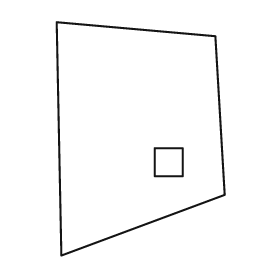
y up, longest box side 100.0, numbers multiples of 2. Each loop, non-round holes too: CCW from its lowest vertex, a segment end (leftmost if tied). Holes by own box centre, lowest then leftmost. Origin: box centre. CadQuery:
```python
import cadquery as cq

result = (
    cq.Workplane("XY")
    .moveTo(-34.0, -50.0)
    .lineTo(36.0, -24.0)
    .lineTo(32.0, 44.0)
    .lineTo(-36.0, 50.0)
    .close()
    .moveTo(6.0, -16.0)
    .lineTo(18.0, -16.0)
    .lineTo(18.0, -4.0)
    .lineTo(6.0, -4.0)
    .close()
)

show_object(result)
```